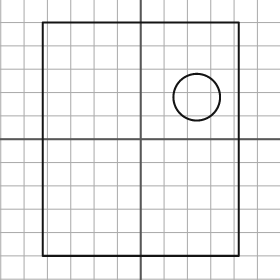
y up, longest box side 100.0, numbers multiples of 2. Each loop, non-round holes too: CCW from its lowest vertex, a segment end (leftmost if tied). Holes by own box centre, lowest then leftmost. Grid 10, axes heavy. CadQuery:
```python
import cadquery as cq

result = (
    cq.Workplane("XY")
    .moveTo(-42.0, -50.0)
    .lineTo(42.0, -50.0)
    .lineTo(42.0, 50.0)
    .lineTo(-42.0, 50.0)
    .close()
    .moveTo(24.0, 18.0)
    .circle(10.0)
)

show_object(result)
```